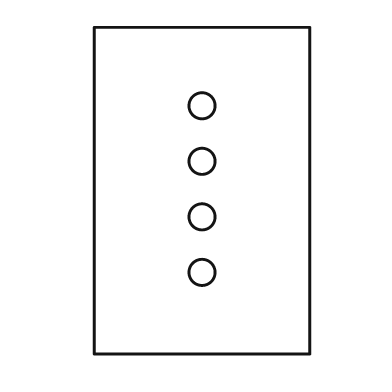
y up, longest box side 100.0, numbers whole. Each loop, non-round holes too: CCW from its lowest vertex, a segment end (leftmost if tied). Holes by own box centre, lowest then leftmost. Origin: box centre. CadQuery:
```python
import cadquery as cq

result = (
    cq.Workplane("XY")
    .moveTo(-33.0, -50.0)
    .lineTo(33.0, -50.0)
    .lineTo(33.0, 50.0)
    .lineTo(-33.0, 50.0)
    .close()
    .moveTo(0.0, -25.0)
    .circle(4.0)
    .moveTo(0.0, -8.0)
    .circle(4.0)
    .moveTo(0.0, 9.0)
    .circle(4.0)
    .moveTo(0.0, 26.0)
    .circle(4.0)
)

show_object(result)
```